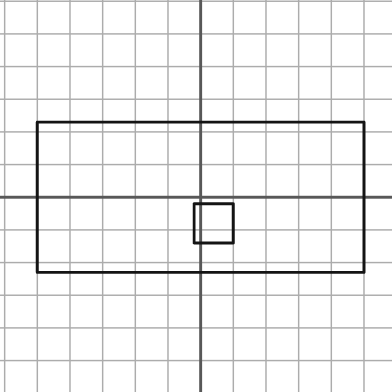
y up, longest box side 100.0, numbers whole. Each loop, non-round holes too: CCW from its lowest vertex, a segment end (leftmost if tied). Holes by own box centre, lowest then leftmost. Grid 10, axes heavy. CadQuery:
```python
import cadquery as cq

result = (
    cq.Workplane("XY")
    .moveTo(-50.0, -23.0)
    .lineTo(50.0, -23.0)
    .lineTo(50.0, 23.0)
    .lineTo(-50.0, 23.0)
    .close()
    .moveTo(-2.0, -14.0)
    .lineTo(10.0, -14.0)
    .lineTo(10.0, -2.0)
    .lineTo(-2.0, -2.0)
    .close()
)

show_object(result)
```